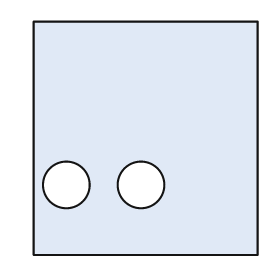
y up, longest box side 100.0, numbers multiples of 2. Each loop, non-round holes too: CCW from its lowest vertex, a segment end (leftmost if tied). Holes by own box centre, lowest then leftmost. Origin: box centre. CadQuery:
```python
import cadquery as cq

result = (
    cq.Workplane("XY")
    .moveTo(-48.0, -50.0)
    .lineTo(48.0, -50.0)
    .lineTo(48.0, 50.0)
    .lineTo(-48.0, 50.0)
    .close()
    .moveTo(-34.0, -20.0)
    .circle(10.0)
    .moveTo(-2.0, -20.0)
    .circle(10.0)
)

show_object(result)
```